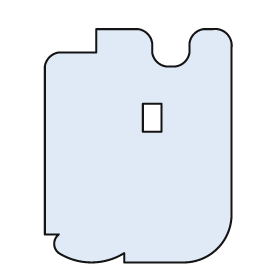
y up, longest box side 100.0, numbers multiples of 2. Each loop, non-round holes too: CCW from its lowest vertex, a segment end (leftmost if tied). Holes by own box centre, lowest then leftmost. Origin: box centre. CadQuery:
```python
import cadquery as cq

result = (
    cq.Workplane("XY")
    .moveTo(-6.0, -50.0)
    .lineTo(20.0, -50.0)
    .threePointArc((34.0, -44.0), (40.0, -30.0))
    .lineTo(40.0, 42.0)
    .threePointArc((38.0, 48.0), (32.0, 50.0))
    .lineTo(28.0, 50.0)
    .threePointArc((24.0, 48.0), (22.0, 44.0))
    .lineTo(22.0, 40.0)
    .threePointArc((20.0, 36.0), (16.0, 34.0))
    .lineTo(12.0, 34.0)
    .threePointArc((8.0, 36.0), (6.0, 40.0))
    .lineTo(6.0, 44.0)
    .threePointArc((4.0, 48.0), (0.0, 50.0))
    .lineTo(-18.0, 50.0)
    .lineTo(-18.0, 40.0)
    .lineTo(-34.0, 40.0)
    .threePointArc((-38.0, 38.0), (-40.0, 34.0))
    .lineTo(-40.0, -38.0)
    .lineTo(-34.0, -38.0)
    .threePointArc((-36.0, -42.0), (-34.0, -46.0))
    .threePointArc((-20.0, -50.0), (-6.0, -46.0))
    .close()
    .moveTo(2.0, 6.0)
    .lineTo(10.0, 6.0)
    .lineTo(10.0, 18.0)
    .lineTo(2.0, 18.0)
    .close()
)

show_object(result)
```